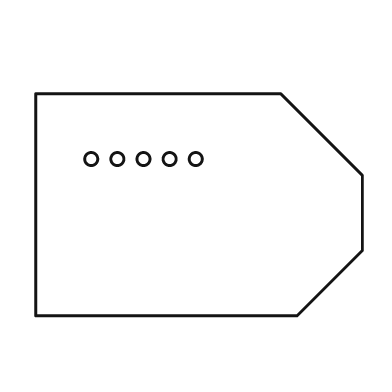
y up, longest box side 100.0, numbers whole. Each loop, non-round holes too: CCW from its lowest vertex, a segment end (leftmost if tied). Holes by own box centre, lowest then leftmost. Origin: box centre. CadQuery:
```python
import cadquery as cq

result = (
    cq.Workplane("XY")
    .moveTo(-50.0, -34.0)
    .lineTo(30.0, -34.0)
    .lineTo(50.0, -14.0)
    .lineTo(50.0, 9.0)
    .lineTo(25.0, 34.0)
    .lineTo(-50.0, 34.0)
    .close()
    .moveTo(-33.0, 14.0)
    .circle(2.0)
    .moveTo(-25.0, 14.0)
    .circle(2.0)
    .moveTo(-17.0, 14.0)
    .circle(2.0)
    .moveTo(-9.0, 14.0)
    .circle(2.0)
    .moveTo(-1.0, 14.0)
    .circle(2.0)
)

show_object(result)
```